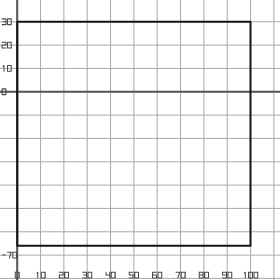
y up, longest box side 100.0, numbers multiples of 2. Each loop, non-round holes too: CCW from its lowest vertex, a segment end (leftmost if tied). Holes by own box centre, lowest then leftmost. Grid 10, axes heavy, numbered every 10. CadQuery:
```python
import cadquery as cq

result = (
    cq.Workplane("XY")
    .moveTo(0.0, -66.0)
    .lineTo(100.0, -66.0)
    .lineTo(100.0, 30.0)
    .lineTo(0.0, 30.0)
    .close()
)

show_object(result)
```